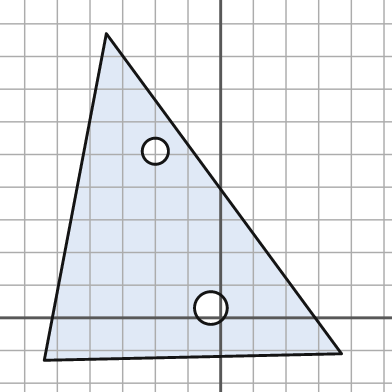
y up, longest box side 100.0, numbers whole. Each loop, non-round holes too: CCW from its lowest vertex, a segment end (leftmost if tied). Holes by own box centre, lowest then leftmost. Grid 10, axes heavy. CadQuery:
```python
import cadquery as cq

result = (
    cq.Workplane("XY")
    .moveTo(-54.0, -13.0)
    .lineTo(37.0, -11.0)
    .lineTo(-35.0, 87.0)
    .close()
    .moveTo(-3.0, 3.0)
    .circle(5.0)
    .moveTo(-20.0, 51.0)
    .circle(4.0)
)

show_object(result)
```